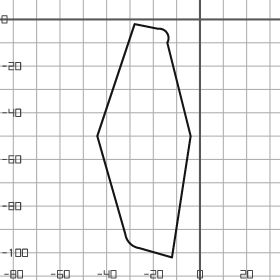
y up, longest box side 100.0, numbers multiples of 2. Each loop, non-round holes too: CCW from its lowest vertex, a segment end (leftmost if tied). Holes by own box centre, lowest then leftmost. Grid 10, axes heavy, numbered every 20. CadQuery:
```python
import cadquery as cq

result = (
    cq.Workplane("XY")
    .moveTo(-12.0, -102.0)
    .lineTo(-4.0, -50.0)
    .lineTo(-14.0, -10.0)
    .threePointArc((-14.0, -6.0), (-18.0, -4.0))
    .lineTo(-28.0, -2.0)
    .lineTo(-44.0, -50.0)
    .lineTo(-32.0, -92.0)
    .threePointArc((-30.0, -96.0), (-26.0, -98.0))
    .close()
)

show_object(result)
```